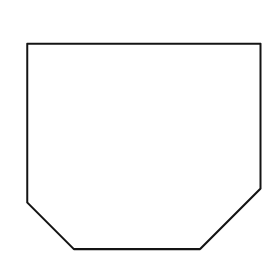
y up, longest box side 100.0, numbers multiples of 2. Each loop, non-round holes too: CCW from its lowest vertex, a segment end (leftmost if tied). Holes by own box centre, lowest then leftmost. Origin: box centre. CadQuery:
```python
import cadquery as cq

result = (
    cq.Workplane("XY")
    .moveTo(-30.0, -44.0)
    .lineTo(24.0, -44.0)
    .lineTo(50.0, -18.0)
    .lineTo(50.0, 44.0)
    .lineTo(-50.0, 44.0)
    .lineTo(-50.0, -24.0)
    .close()
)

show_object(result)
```